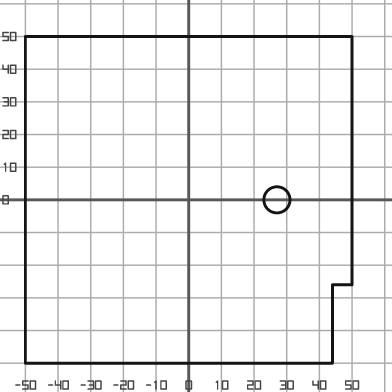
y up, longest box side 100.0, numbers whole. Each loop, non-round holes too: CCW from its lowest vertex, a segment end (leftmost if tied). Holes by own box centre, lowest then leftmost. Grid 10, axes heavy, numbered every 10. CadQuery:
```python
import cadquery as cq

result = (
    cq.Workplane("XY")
    .moveTo(-50.0, -50.0)
    .lineTo(44.0, -50.0)
    .lineTo(44.0, -26.0)
    .lineTo(50.0, -26.0)
    .lineTo(50.0, 50.0)
    .lineTo(-50.0, 50.0)
    .close()
    .moveTo(27.0, 0.0)
    .circle(4.0)
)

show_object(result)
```